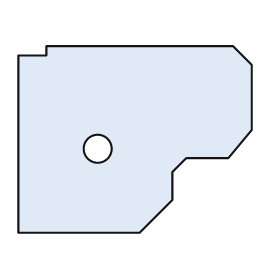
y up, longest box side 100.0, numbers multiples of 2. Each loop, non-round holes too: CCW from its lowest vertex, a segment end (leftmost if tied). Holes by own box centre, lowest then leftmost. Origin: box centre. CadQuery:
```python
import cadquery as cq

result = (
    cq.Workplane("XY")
    .moveTo(-50.0, -40.0)
    .lineTo(2.0, -40.0)
    .lineTo(16.0, -26.0)
    .lineTo(16.0, -14.0)
    .lineTo(22.0, -8.0)
    .lineTo(40.0, -8.0)
    .lineTo(50.0, 4.0)
    .lineTo(50.0, 32.0)
    .lineTo(42.0, 40.0)
    .lineTo(-38.0, 40.0)
    .lineTo(-38.0, 36.0)
    .lineTo(-50.0, 36.0)
    .close()
    .moveTo(-16.0, -4.0)
    .circle(6.0)
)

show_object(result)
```